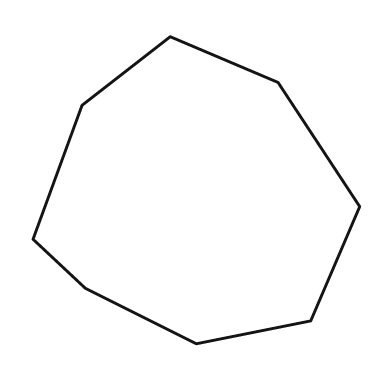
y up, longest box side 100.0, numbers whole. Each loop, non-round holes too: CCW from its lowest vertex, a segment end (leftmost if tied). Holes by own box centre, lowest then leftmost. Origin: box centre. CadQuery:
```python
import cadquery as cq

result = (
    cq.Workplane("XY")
    .moveTo(0.0, -47.0)
    .lineTo(35.0, -40.0)
    .lineTo(50.0, -5.0)
    .lineTo(25.0, 33.0)
    .lineTo(-8.0, 47.0)
    .lineTo(-35.0, 26.0)
    .lineTo(-50.0, -15.0)
    .lineTo(-34.0, -30.0)
    .close()
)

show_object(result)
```